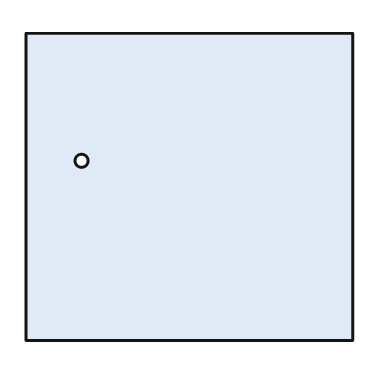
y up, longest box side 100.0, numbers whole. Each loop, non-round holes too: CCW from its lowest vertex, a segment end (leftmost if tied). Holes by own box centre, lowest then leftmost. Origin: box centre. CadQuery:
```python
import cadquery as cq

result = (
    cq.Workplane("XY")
    .moveTo(-50.0, -47.0)
    .lineTo(50.0, -47.0)
    .lineTo(50.0, 47.0)
    .lineTo(-50.0, 47.0)
    .close()
    .moveTo(-33.0, 8.0)
    .circle(2.0)
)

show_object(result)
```